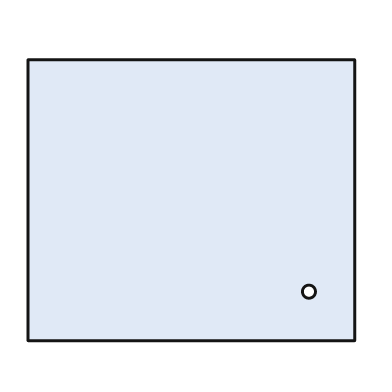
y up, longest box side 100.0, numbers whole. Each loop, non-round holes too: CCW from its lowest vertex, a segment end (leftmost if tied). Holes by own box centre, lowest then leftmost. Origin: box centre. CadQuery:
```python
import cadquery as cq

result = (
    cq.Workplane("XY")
    .moveTo(-50.0, -43.0)
    .lineTo(50.0, -43.0)
    .lineTo(50.0, 43.0)
    .lineTo(-50.0, 43.0)
    .close()
    .moveTo(36.0, -28.0)
    .circle(2.0)
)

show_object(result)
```